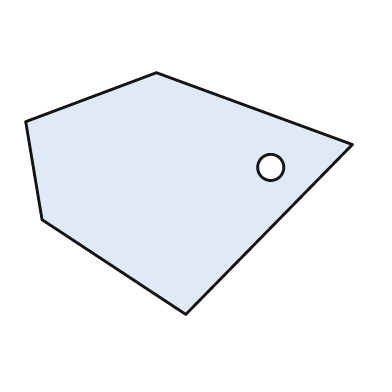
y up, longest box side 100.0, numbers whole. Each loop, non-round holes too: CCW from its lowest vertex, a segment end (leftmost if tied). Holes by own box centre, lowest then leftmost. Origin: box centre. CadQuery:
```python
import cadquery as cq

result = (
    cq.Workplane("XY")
    .moveTo(-1.0, -37.0)
    .lineTo(50.0, 15.0)
    .lineTo(-10.0, 37.0)
    .lineTo(-50.0, 22.0)
    .lineTo(-45.0, -8.0)
    .close()
    .moveTo(25.0, 8.0)
    .circle(4.0)
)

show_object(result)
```